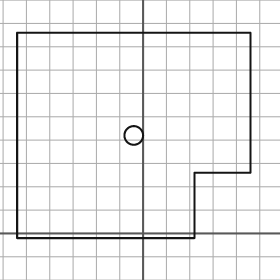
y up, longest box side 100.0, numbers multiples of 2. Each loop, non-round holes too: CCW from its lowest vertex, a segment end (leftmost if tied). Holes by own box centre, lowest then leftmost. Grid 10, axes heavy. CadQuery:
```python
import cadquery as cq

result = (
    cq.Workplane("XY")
    .moveTo(-54.0, -2.0)
    .lineTo(22.0, -2.0)
    .lineTo(22.0, 26.0)
    .lineTo(46.0, 26.0)
    .lineTo(46.0, 86.0)
    .lineTo(-54.0, 86.0)
    .close()
    .moveTo(-4.0, 42.0)
    .circle(4.0)
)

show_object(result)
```